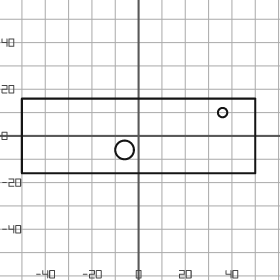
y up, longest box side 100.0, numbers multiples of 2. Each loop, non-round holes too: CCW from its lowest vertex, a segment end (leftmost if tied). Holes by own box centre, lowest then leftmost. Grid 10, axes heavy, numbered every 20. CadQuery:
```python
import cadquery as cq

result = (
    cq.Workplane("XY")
    .moveTo(-50.0, -16.0)
    .lineTo(50.0, -16.0)
    .lineTo(50.0, 16.0)
    .lineTo(-50.0, 16.0)
    .close()
    .moveTo(-6.0, -6.0)
    .circle(4.0)
    .moveTo(36.0, 10.0)
    .circle(2.0)
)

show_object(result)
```